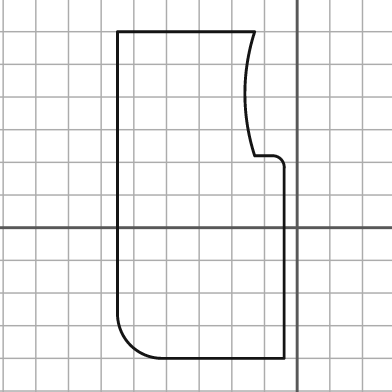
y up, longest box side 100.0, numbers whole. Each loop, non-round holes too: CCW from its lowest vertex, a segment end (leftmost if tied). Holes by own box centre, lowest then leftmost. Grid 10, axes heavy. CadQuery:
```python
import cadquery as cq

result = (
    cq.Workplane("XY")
    .moveTo(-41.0, -40.0)
    .lineTo(-4.0, -40.0)
    .lineTo(-4.0, 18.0)
    .threePointArc((-5.0, 21.0), (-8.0, 22.0))
    .lineTo(-13.0, 22.0)
    .threePointArc((-16.0, 41.0), (-13.0, 60.0))
    .lineTo(-55.0, 60.0)
    .lineTo(-55.0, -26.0)
    .threePointArc((-51.0, -36.0), (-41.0, -40.0))
    .close()
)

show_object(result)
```